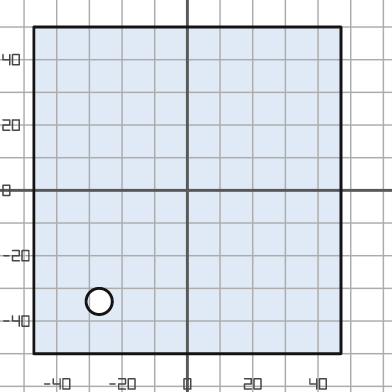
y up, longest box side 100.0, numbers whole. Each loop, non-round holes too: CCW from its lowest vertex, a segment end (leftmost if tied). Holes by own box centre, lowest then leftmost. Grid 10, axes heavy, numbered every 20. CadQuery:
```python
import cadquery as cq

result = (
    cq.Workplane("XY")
    .moveTo(-47.0, -50.0)
    .lineTo(47.0, -50.0)
    .lineTo(47.0, 50.0)
    .lineTo(-47.0, 50.0)
    .close()
    .moveTo(-27.0, -34.0)
    .circle(4.0)
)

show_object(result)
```